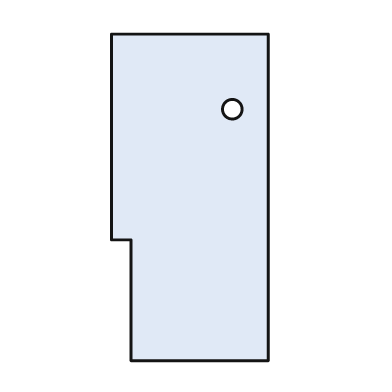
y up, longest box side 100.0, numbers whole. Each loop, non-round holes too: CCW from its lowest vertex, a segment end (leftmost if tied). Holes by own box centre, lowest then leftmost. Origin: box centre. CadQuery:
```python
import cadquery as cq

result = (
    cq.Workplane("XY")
    .moveTo(-18.0, -50.0)
    .lineTo(24.0, -50.0)
    .lineTo(24.0, 50.0)
    .lineTo(-24.0, 50.0)
    .lineTo(-24.0, -13.0)
    .lineTo(-18.0, -13.0)
    .close()
    .moveTo(13.0, 27.0)
    .circle(3.0)
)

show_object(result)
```